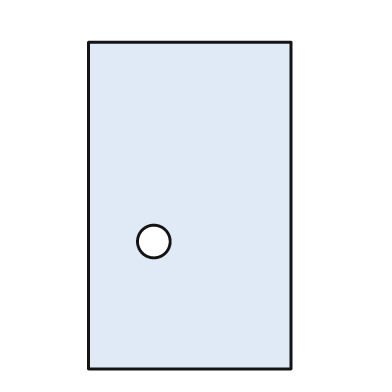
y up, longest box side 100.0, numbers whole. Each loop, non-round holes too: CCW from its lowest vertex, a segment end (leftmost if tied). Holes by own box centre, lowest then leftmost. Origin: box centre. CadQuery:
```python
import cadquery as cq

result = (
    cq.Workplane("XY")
    .moveTo(-31.0, -50.0)
    .lineTo(31.0, -50.0)
    .lineTo(31.0, 50.0)
    .lineTo(-31.0, 50.0)
    .close()
    .moveTo(-11.0, -11.0)
    .circle(5.0)
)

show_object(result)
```